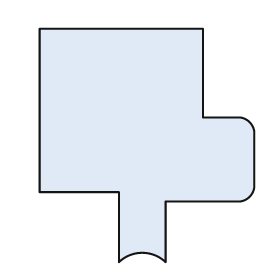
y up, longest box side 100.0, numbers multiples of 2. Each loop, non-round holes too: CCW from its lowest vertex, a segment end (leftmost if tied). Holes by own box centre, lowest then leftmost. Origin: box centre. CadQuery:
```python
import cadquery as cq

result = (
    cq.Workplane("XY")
    .moveTo(-12.0, -50.0)
    .threePointArc((-2.0, -46.0), (8.0, -50.0))
    .lineTo(8.0, -24.0)
    .lineTo(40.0, -24.0)
    .threePointArc((44.0, -22.0), (46.0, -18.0))
    .lineTo(46.0, 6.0)
    .threePointArc((44.0, 10.0), (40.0, 12.0))
    .lineTo(24.0, 12.0)
    .lineTo(24.0, 50.0)
    .lineTo(-46.0, 50.0)
    .lineTo(-46.0, -20.0)
    .lineTo(-12.0, -20.0)
    .close()
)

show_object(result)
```